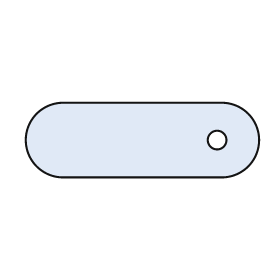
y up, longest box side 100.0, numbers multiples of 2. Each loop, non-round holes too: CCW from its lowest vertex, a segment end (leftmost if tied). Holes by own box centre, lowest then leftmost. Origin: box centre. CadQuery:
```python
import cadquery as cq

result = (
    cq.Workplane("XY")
    .moveTo(-34.0, -16.0)
    .lineTo(34.0, -16.0)
    .threePointArc((50.0, 0.0), (34.0, 16.0))
    .lineTo(-34.0, 16.0)
    .threePointArc((-50.0, 0.0), (-34.0, -16.0))
    .close()
    .moveTo(32.0, 0.0)
    .circle(4.0)
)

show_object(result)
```